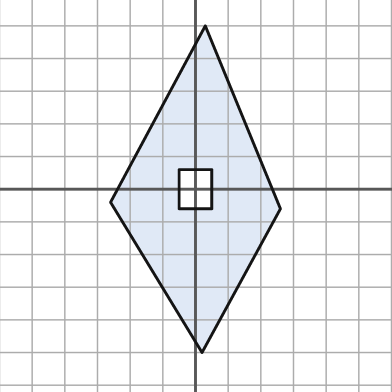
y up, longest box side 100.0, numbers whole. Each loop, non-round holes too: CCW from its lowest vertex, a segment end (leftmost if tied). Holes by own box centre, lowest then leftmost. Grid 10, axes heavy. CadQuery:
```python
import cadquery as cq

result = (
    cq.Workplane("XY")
    .moveTo(2.0, -50.0)
    .lineTo(26.0, -6.0)
    .lineTo(3.0, 50.0)
    .lineTo(-26.0, -4.0)
    .close()
    .moveTo(-5.0, -6.0)
    .lineTo(5.0, -6.0)
    .lineTo(5.0, 6.0)
    .lineTo(-5.0, 6.0)
    .close()
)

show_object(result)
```